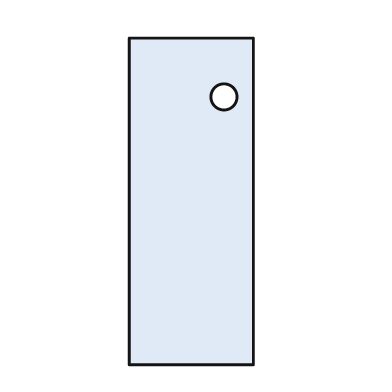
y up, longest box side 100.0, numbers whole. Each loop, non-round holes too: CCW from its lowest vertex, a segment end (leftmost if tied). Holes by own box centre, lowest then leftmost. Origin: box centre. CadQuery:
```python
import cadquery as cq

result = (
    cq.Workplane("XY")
    .moveTo(-19.0, -50.0)
    .lineTo(19.0, -50.0)
    .lineTo(19.0, 50.0)
    .lineTo(-19.0, 50.0)
    .close()
    .moveTo(10.0, 32.0)
    .circle(4.0)
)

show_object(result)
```